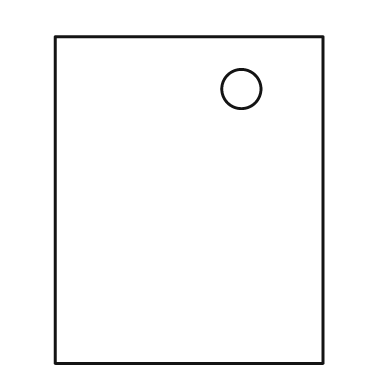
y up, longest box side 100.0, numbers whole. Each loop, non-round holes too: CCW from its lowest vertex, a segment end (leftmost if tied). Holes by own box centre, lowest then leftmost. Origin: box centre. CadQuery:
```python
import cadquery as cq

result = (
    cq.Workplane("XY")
    .moveTo(-41.0, -50.0)
    .lineTo(41.0, -50.0)
    .lineTo(41.0, 50.0)
    .lineTo(-41.0, 50.0)
    .close()
    .moveTo(16.0, 34.0)
    .circle(6.0)
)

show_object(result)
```